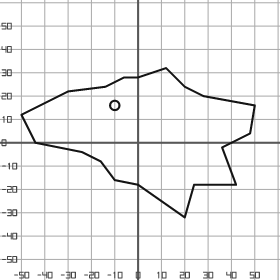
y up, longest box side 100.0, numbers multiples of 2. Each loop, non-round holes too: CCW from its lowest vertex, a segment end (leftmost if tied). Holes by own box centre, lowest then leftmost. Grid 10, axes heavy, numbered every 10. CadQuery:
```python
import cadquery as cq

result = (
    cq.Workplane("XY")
    .moveTo(20.0, -32.0)
    .lineTo(24.0, -18.0)
    .lineTo(42.0, -18.0)
    .lineTo(36.0, -2.0)
    .lineTo(48.0, 4.0)
    .lineTo(50.0, 16.0)
    .lineTo(28.0, 20.0)
    .lineTo(20.0, 24.0)
    .lineTo(12.0, 32.0)
    .lineTo(0.0, 28.0)
    .lineTo(-6.0, 28.0)
    .lineTo(-14.0, 24.0)
    .lineTo(-30.0, 22.0)
    .lineTo(-50.0, 12.0)
    .lineTo(-44.0, 0.0)
    .lineTo(-24.0, -4.0)
    .lineTo(-16.0, -8.0)
    .lineTo(-10.0, -16.0)
    .lineTo(0.0, -18.0)
    .close()
    .moveTo(-10.0, 16.0)
    .circle(2.0)
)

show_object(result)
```